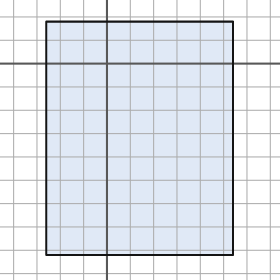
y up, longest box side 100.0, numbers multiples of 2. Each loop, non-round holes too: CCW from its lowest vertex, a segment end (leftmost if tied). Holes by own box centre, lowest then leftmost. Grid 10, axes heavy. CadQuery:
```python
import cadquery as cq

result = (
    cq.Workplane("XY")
    .moveTo(-26.0, -82.0)
    .lineTo(54.0, -82.0)
    .lineTo(54.0, 18.0)
    .lineTo(-26.0, 18.0)
    .close()
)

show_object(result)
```